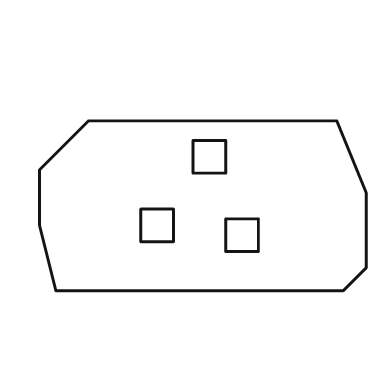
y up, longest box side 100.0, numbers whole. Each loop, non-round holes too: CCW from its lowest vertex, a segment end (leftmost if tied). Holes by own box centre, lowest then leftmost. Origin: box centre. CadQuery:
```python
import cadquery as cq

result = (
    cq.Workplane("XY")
    .moveTo(-45.0, -26.0)
    .lineTo(43.0, -26.0)
    .lineTo(50.0, -19.0)
    .lineTo(50.0, 4.0)
    .lineTo(41.0, 26.0)
    .lineTo(-35.0, 26.0)
    .lineTo(-50.0, 11.0)
    .lineTo(-50.0, -6.0)
    .close()
    .moveTo(7.0, -14.0)
    .lineTo(17.0, -14.0)
    .lineTo(17.0, -4.0)
    .lineTo(7.0, -4.0)
    .close()
    .moveTo(-19.0, -11.0)
    .lineTo(-9.0, -11.0)
    .lineTo(-9.0, -1.0)
    .lineTo(-19.0, -1.0)
    .close()
    .moveTo(-3.0, 10.0)
    .lineTo(7.0, 10.0)
    .lineTo(7.0, 20.0)
    .lineTo(-3.0, 20.0)
    .close()
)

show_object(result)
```